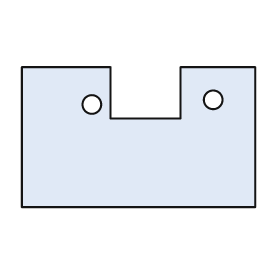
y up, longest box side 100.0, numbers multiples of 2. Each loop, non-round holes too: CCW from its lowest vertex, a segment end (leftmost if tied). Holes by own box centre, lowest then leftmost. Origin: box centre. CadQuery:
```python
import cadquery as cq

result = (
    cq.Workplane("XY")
    .moveTo(-50.0, -30.0)
    .lineTo(50.0, -30.0)
    .lineTo(50.0, 30.0)
    .lineTo(18.0, 30.0)
    .lineTo(18.0, 8.0)
    .lineTo(-12.0, 8.0)
    .lineTo(-12.0, 30.0)
    .lineTo(-50.0, 30.0)
    .close()
    .moveTo(-20.0, 14.0)
    .circle(4.0)
    .moveTo(32.0, 16.0)
    .circle(4.0)
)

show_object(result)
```